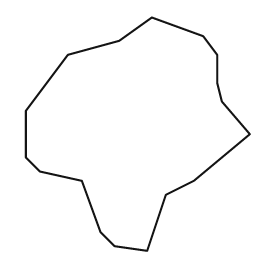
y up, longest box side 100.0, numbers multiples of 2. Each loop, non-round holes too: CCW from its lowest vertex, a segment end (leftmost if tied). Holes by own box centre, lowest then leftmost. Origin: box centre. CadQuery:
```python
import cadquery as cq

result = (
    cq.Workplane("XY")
    .moveTo(4.0, -50.0)
    .lineTo(12.0, -26.0)
    .lineTo(24.0, -20.0)
    .lineTo(48.0, 0.0)
    .lineTo(36.0, 14.0)
    .lineTo(34.0, 22.0)
    .lineTo(34.0, 34.0)
    .lineTo(28.0, 42.0)
    .lineTo(6.0, 50.0)
    .lineTo(-8.0, 40.0)
    .lineTo(-30.0, 34.0)
    .lineTo(-48.0, 10.0)
    .lineTo(-48.0, -10.0)
    .lineTo(-42.0, -16.0)
    .lineTo(-24.0, -20.0)
    .lineTo(-16.0, -42.0)
    .lineTo(-10.0, -48.0)
    .close()
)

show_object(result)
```